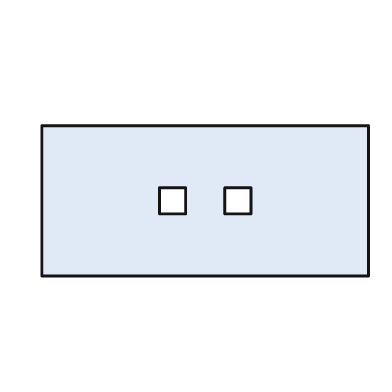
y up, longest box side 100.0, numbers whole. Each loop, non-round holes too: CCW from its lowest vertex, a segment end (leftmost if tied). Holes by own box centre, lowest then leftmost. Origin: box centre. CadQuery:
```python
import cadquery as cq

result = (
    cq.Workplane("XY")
    .moveTo(-50.0, -23.0)
    .lineTo(50.0, -23.0)
    .lineTo(50.0, 23.0)
    .lineTo(-50.0, 23.0)
    .close()
    .moveTo(-14.0, -4.0)
    .lineTo(-6.0, -4.0)
    .lineTo(-6.0, 4.0)
    .lineTo(-14.0, 4.0)
    .close()
    .moveTo(6.0, -4.0)
    .lineTo(14.0, -4.0)
    .lineTo(14.0, 4.0)
    .lineTo(6.0, 4.0)
    .close()
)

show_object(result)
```